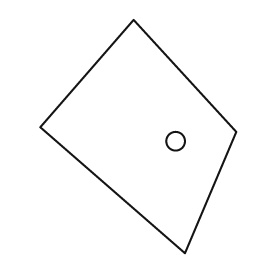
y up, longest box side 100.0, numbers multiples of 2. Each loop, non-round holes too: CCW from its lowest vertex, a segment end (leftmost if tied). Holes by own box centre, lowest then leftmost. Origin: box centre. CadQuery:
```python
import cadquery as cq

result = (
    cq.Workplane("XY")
    .moveTo(20.0, -50.0)
    .lineTo(42.0, 2.0)
    .lineTo(-2.0, 50.0)
    .lineTo(-42.0, 4.0)
    .close()
    .moveTo(16.0, -2.0)
    .circle(4.0)
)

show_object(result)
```